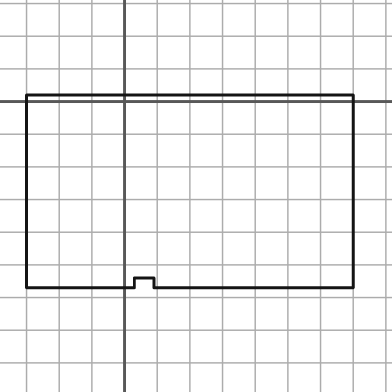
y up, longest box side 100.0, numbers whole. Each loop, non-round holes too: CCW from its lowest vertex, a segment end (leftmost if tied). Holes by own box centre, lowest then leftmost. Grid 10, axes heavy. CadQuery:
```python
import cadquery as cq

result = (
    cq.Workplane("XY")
    .moveTo(-30.0, -57.0)
    .lineTo(3.0, -57.0)
    .lineTo(3.0, -54.0)
    .lineTo(9.0, -54.0)
    .lineTo(9.0, -57.0)
    .lineTo(70.0, -57.0)
    .lineTo(70.0, 2.0)
    .lineTo(-30.0, 2.0)
    .close()
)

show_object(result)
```